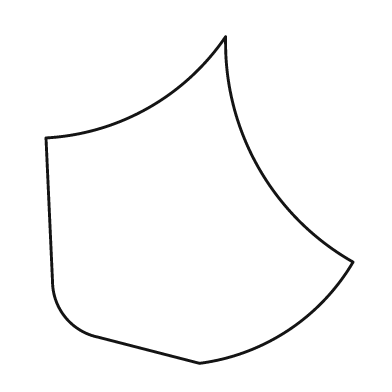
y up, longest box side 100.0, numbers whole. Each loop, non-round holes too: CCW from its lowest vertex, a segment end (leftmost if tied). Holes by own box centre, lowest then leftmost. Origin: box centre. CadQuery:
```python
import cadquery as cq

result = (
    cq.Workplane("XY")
    .moveTo(0.0, -50.0)
    .threePointArc((27.0, -40.0), (47.0, -19.0))
    .threePointArc((18.0, 10.0), (8.0, 50.0))
    .threePointArc((-16.0, 28.0), (-47.0, 19.0))
    .lineTo(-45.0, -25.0)
    .threePointArc((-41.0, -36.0), (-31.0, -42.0))
    .close()
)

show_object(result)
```